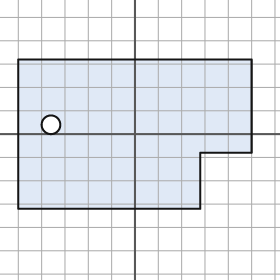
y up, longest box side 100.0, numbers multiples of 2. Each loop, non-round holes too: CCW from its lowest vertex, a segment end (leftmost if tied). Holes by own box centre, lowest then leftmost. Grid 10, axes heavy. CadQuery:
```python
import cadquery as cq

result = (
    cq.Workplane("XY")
    .moveTo(-50.0, -32.0)
    .lineTo(28.0, -32.0)
    .lineTo(28.0, -8.0)
    .lineTo(50.0, -8.0)
    .lineTo(50.0, 32.0)
    .lineTo(-50.0, 32.0)
    .close()
    .moveTo(-36.0, 4.0)
    .circle(4.0)
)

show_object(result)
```